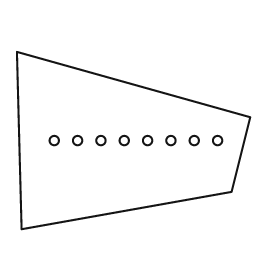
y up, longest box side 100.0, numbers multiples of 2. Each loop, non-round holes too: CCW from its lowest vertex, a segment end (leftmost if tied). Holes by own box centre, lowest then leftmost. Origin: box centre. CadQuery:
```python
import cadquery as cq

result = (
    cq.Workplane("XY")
    .moveTo(-48.0, -38.0)
    .lineTo(42.0, -22.0)
    .lineTo(50.0, 10.0)
    .lineTo(-50.0, 38.0)
    .close()
    .moveTo(-34.0, 0.0)
    .circle(2.0)
    .moveTo(-24.0, 0.0)
    .circle(2.0)
    .moveTo(-14.0, 0.0)
    .circle(2.0)
    .moveTo(-4.0, 0.0)
    .circle(2.0)
    .moveTo(6.0, 0.0)
    .circle(2.0)
    .moveTo(16.0, 0.0)
    .circle(2.0)
    .moveTo(26.0, 0.0)
    .circle(2.0)
    .moveTo(36.0, 0.0)
    .circle(2.0)
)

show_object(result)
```